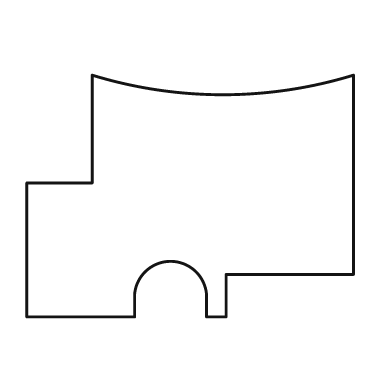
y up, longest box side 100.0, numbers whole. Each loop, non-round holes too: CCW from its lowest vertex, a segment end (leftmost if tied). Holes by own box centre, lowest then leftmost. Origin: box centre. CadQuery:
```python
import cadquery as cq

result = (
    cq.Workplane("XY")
    .moveTo(-50.0, -37.0)
    .lineTo(-17.0, -37.0)
    .lineTo(-17.0, -30.0)
    .threePointArc((-6.0, -20.0), (5.0, -30.0))
    .lineTo(5.0, -37.0)
    .lineTo(11.0, -37.0)
    .lineTo(11.0, -24.0)
    .lineTo(50.0, -24.0)
    .lineTo(50.0, 37.0)
    .threePointArc((10.0, 31.0), (-30.0, 37.0))
    .lineTo(-30.0, 4.0)
    .lineTo(-50.0, 4.0)
    .close()
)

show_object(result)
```